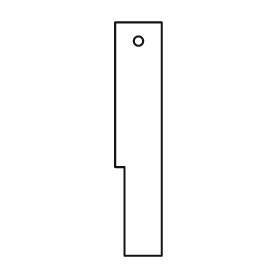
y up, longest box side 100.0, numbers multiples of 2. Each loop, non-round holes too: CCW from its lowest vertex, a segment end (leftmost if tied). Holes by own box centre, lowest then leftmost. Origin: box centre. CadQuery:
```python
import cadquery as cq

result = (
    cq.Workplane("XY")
    .moveTo(-6.0, -50.0)
    .lineTo(10.0, -50.0)
    .lineTo(10.0, 50.0)
    .lineTo(-10.0, 50.0)
    .lineTo(-10.0, -12.0)
    .lineTo(-6.0, -12.0)
    .close()
    .moveTo(0.0, 42.0)
    .circle(2.0)
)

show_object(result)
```